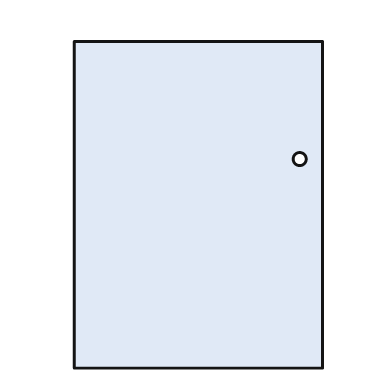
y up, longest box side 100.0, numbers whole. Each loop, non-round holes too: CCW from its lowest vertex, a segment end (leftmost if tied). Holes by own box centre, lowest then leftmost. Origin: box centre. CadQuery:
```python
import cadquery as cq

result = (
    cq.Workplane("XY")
    .moveTo(-38.0, -50.0)
    .lineTo(38.0, -50.0)
    .lineTo(38.0, 50.0)
    .lineTo(-38.0, 50.0)
    .close()
    .moveTo(31.0, 14.0)
    .circle(2.0)
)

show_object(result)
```